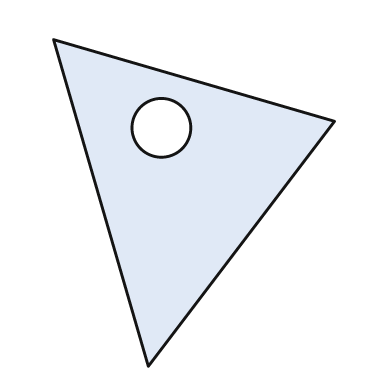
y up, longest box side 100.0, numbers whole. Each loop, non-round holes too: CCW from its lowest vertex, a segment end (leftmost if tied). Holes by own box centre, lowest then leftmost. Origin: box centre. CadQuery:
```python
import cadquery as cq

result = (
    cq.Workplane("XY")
    .moveTo(-14.0, -50.0)
    .lineTo(43.0, 25.0)
    .lineTo(-43.0, 50.0)
    .close()
    .moveTo(-10.0, 23.0)
    .circle(9.0)
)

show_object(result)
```